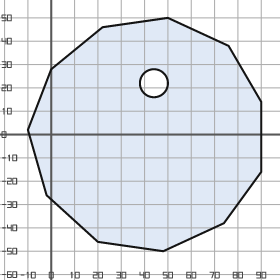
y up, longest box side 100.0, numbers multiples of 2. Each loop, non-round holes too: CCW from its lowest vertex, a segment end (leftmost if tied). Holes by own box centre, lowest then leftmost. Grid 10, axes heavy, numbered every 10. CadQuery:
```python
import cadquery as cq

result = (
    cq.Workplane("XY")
    .moveTo(48.0, -50.0)
    .lineTo(74.0, -38.0)
    .lineTo(90.0, -16.0)
    .lineTo(90.0, 14.0)
    .lineTo(76.0, 38.0)
    .lineTo(50.0, 50.0)
    .lineTo(22.0, 46.0)
    .lineTo(0.0, 28.0)
    .lineTo(-10.0, 2.0)
    .lineTo(-2.0, -26.0)
    .lineTo(20.0, -46.0)
    .close()
    .moveTo(44.0, 22.0)
    .circle(6.0)
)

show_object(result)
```